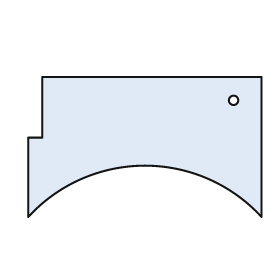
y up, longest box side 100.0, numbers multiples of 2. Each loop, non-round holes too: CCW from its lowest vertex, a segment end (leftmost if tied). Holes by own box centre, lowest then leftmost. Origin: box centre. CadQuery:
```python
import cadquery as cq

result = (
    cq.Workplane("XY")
    .moveTo(-50.0, -30.0)
    .threePointArc((0.0, -8.0), (50.0, -30.0))
    .lineTo(50.0, 30.0)
    .lineTo(-44.0, 30.0)
    .lineTo(-44.0, 4.0)
    .lineTo(-50.0, 4.0)
    .close()
    .moveTo(38.0, 20.0)
    .circle(2.0)
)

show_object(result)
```